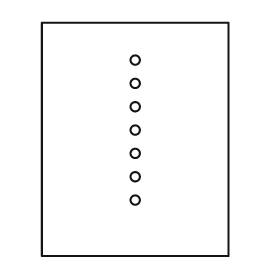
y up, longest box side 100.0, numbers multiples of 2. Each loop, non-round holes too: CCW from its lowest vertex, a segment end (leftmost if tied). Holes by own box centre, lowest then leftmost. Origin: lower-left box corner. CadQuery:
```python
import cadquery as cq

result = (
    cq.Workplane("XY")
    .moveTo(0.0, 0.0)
    .lineTo(80.0, 0.0)
    .lineTo(80.0, 100.0)
    .lineTo(0.0, 100.0)
    .close()
    .moveTo(40.0, 24.0)
    .circle(2.0)
    .moveTo(40.0, 34.0)
    .circle(2.0)
    .moveTo(40.0, 44.0)
    .circle(2.0)
    .moveTo(40.0, 54.0)
    .circle(2.0)
    .moveTo(40.0, 64.0)
    .circle(2.0)
    .moveTo(40.0, 74.0)
    .circle(2.0)
    .moveTo(40.0, 84.0)
    .circle(2.0)
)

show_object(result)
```